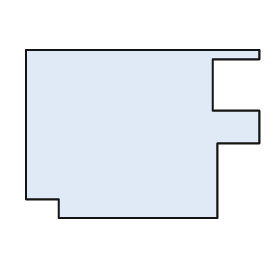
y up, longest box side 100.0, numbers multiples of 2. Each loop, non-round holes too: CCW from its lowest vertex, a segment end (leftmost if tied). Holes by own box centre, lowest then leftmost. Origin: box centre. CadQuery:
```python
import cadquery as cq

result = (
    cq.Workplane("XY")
    .moveTo(-36.0, -36.0)
    .lineTo(32.0, -36.0)
    .lineTo(32.0, -4.0)
    .lineTo(50.0, -4.0)
    .lineTo(50.0, 10.0)
    .lineTo(30.0, 10.0)
    .lineTo(30.0, 32.0)
    .lineTo(50.0, 32.0)
    .lineTo(50.0, 36.0)
    .lineTo(-50.0, 36.0)
    .lineTo(-50.0, -28.0)
    .lineTo(-36.0, -28.0)
    .close()
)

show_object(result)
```